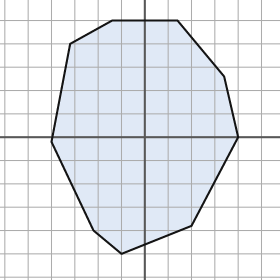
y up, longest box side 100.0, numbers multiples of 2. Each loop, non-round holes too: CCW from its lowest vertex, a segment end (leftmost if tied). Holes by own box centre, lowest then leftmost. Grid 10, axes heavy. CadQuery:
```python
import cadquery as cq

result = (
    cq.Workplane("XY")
    .moveTo(-10.0, -50.0)
    .lineTo(20.0, -38.0)
    .lineTo(40.0, 0.0)
    .lineTo(34.0, 26.0)
    .lineTo(14.0, 50.0)
    .lineTo(-14.0, 50.0)
    .lineTo(-32.0, 40.0)
    .lineTo(-40.0, -2.0)
    .lineTo(-22.0, -40.0)
    .close()
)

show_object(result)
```